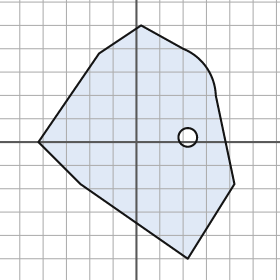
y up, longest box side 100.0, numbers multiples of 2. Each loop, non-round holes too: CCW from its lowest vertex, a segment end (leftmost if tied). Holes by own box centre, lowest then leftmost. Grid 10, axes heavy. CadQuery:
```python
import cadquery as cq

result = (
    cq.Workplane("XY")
    .moveTo(22.0, -50.0)
    .lineTo(42.0, -18.0)
    .lineTo(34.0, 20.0)
    .threePointArc((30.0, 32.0), (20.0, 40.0))
    .lineTo(2.0, 50.0)
    .lineTo(-16.0, 38.0)
    .lineTo(-42.0, 0.0)
    .lineTo(-24.0, -18.0)
    .close()
    .moveTo(22.0, 2.0)
    .circle(4.0)
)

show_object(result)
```